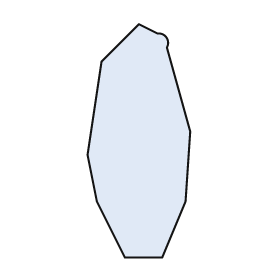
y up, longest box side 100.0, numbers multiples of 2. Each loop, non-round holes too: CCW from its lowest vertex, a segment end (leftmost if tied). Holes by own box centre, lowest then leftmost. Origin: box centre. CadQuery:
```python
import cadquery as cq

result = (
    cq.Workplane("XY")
    .moveTo(-6.0, -50.0)
    .lineTo(10.0, -50.0)
    .lineTo(20.0, -26.0)
    .lineTo(22.0, 4.0)
    .lineTo(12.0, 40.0)
    .threePointArc((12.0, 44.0), (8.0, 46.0))
    .lineTo(0.0, 50.0)
    .lineTo(-16.0, 34.0)
    .lineTo(-22.0, -6.0)
    .lineTo(-18.0, -26.0)
    .close()
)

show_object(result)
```